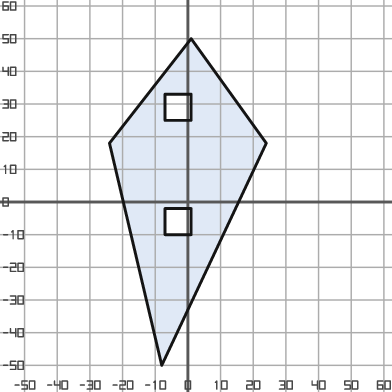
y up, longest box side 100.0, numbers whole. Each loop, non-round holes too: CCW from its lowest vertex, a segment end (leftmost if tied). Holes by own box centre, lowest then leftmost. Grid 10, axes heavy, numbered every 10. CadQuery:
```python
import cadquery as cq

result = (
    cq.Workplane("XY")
    .moveTo(-8.0, -50.0)
    .lineTo(24.0, 18.0)
    .lineTo(1.0, 50.0)
    .lineTo(-24.0, 18.0)
    .close()
    .moveTo(-7.0, -10.0)
    .lineTo(1.0, -10.0)
    .lineTo(1.0, -2.0)
    .lineTo(-7.0, -2.0)
    .close()
    .moveTo(-7.0, 25.0)
    .lineTo(1.0, 25.0)
    .lineTo(1.0, 33.0)
    .lineTo(-7.0, 33.0)
    .close()
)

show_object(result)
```